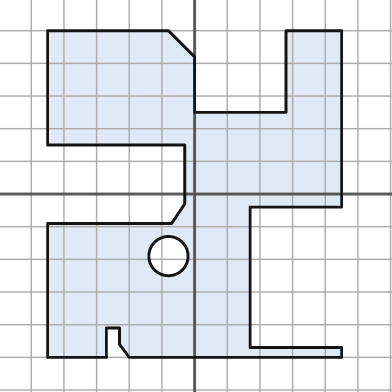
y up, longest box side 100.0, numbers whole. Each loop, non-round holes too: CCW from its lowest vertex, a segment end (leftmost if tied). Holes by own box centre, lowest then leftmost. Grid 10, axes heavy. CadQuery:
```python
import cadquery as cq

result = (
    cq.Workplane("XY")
    .moveTo(-45.0, -50.0)
    .lineTo(-27.0, -50.0)
    .lineTo(-27.0, -41.0)
    .lineTo(-23.0, -41.0)
    .lineTo(-23.0, -46.0)
    .lineTo(-20.0, -50.0)
    .lineTo(45.0, -50.0)
    .lineTo(45.0, -47.0)
    .lineTo(17.0, -47.0)
    .lineTo(17.0, -4.0)
    .lineTo(45.0, -4.0)
    .lineTo(45.0, 50.0)
    .lineTo(28.0, 50.0)
    .lineTo(28.0, 25.0)
    .lineTo(0.0, 25.0)
    .lineTo(0.0, 42.0)
    .lineTo(-8.0, 50.0)
    .lineTo(-45.0, 50.0)
    .lineTo(-45.0, 15.0)
    .lineTo(-3.0, 15.0)
    .lineTo(-3.0, -3.0)
    .lineTo(-7.0, -9.0)
    .lineTo(-45.0, -9.0)
    .close()
    .moveTo(-8.0, -19.0)
    .circle(6.0)
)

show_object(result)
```